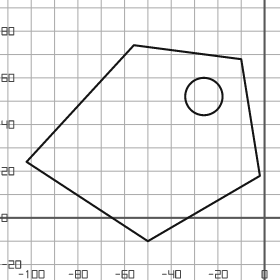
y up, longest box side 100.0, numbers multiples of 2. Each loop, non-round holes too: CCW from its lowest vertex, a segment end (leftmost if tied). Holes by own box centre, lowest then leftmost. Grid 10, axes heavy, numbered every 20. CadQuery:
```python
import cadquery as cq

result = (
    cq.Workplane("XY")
    .moveTo(-50.0, -10.0)
    .lineTo(-2.0, 18.0)
    .lineTo(-10.0, 68.0)
    .lineTo(-56.0, 74.0)
    .lineTo(-102.0, 24.0)
    .close()
    .moveTo(-26.0, 52.0)
    .circle(8.0)
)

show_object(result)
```